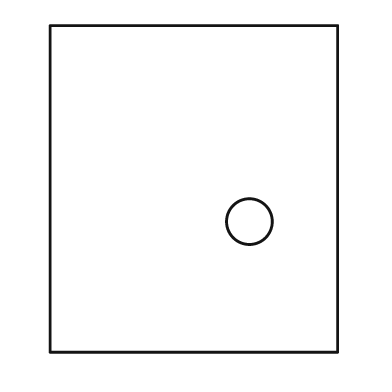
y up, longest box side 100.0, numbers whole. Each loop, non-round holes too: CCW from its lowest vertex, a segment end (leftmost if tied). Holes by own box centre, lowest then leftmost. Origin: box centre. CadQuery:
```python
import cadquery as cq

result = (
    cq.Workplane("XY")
    .moveTo(-44.0, -50.0)
    .lineTo(44.0, -50.0)
    .lineTo(44.0, 50.0)
    .lineTo(-44.0, 50.0)
    .close()
    .moveTo(17.0, -10.0)
    .circle(7.0)
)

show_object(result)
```